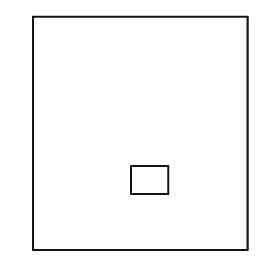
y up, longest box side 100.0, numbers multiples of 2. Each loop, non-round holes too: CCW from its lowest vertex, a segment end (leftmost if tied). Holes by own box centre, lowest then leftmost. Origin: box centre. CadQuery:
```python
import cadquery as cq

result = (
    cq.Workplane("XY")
    .moveTo(-46.0, -50.0)
    .lineTo(46.0, -50.0)
    .lineTo(46.0, 50.0)
    .lineTo(-46.0, 50.0)
    .close()
    .moveTo(-4.0, -26.0)
    .lineTo(12.0, -26.0)
    .lineTo(12.0, -14.0)
    .lineTo(-4.0, -14.0)
    .close()
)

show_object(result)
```